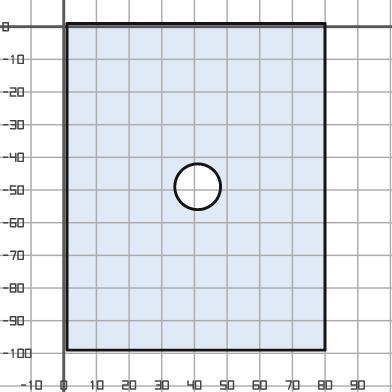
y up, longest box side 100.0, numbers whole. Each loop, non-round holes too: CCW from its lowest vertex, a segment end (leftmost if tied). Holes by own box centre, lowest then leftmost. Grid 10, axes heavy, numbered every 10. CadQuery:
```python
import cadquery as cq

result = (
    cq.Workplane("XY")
    .moveTo(1.0, -99.0)
    .lineTo(80.0, -99.0)
    .lineTo(80.0, 1.0)
    .lineTo(1.0, 1.0)
    .close()
    .moveTo(41.0, -49.0)
    .circle(7.0)
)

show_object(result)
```